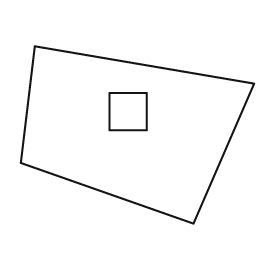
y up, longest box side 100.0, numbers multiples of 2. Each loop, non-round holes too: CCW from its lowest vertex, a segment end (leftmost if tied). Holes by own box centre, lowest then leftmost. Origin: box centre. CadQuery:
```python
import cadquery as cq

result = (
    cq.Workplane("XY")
    .moveTo(24.0, -38.0)
    .lineTo(50.0, 22.0)
    .lineTo(-44.0, 38.0)
    .lineTo(-50.0, -12.0)
    .close()
    .moveTo(-12.0, 2.0)
    .lineTo(4.0, 2.0)
    .lineTo(4.0, 18.0)
    .lineTo(-12.0, 18.0)
    .close()
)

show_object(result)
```